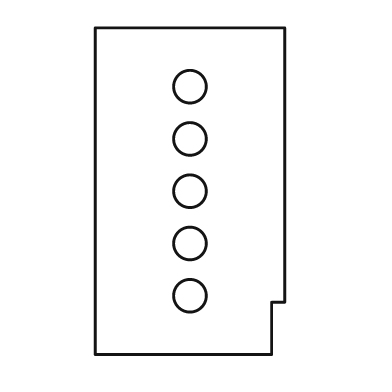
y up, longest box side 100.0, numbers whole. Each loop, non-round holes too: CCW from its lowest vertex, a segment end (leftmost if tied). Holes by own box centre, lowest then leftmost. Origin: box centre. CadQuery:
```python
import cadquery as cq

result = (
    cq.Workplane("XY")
    .moveTo(-29.0, -50.0)
    .lineTo(25.0, -50.0)
    .lineTo(25.0, -34.0)
    .lineTo(29.0, -34.0)
    .lineTo(29.0, 50.0)
    .lineTo(-29.0, 50.0)
    .close()
    .moveTo(0.0, -32.0)
    .circle(5.0)
    .moveTo(0.0, -16.0)
    .circle(5.0)
    .moveTo(0.0, 0.0)
    .circle(5.0)
    .moveTo(0.0, 16.0)
    .circle(5.0)
    .moveTo(0.0, 32.0)
    .circle(5.0)
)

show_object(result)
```